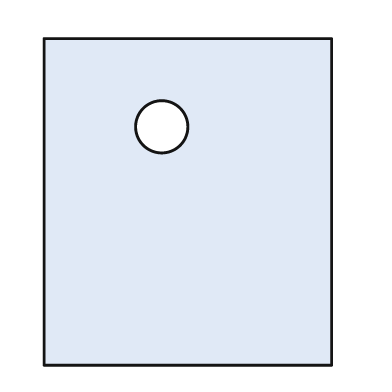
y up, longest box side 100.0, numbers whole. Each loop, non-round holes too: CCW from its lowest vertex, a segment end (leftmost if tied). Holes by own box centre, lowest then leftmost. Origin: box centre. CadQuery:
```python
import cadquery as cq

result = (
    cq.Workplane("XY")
    .moveTo(-44.0, -50.0)
    .lineTo(44.0, -50.0)
    .lineTo(44.0, 50.0)
    .lineTo(-44.0, 50.0)
    .close()
    .moveTo(-8.0, 23.0)
    .circle(8.0)
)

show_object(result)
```